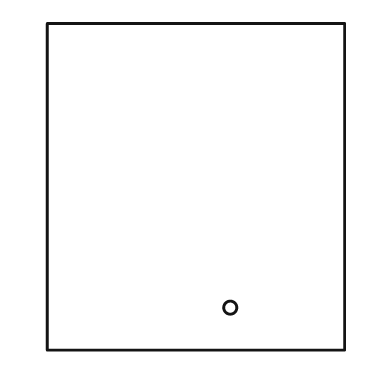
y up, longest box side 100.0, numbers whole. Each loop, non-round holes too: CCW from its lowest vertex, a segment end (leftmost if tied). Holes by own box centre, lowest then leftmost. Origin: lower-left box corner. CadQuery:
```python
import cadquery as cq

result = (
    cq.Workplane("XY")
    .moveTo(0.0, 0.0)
    .lineTo(91.0, 0.0)
    .lineTo(91.0, 100.0)
    .lineTo(0.0, 100.0)
    .close()
    .moveTo(56.0, 13.0)
    .circle(2.0)
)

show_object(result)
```